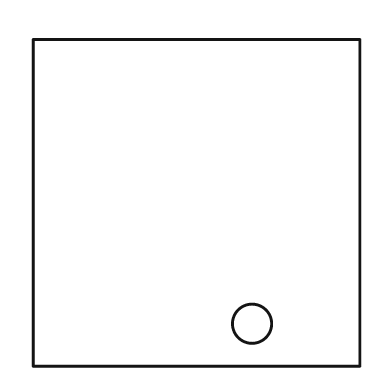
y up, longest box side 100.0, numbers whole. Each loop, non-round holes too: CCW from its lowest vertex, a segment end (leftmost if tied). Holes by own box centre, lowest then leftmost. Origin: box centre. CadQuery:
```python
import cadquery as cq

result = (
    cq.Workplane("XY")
    .moveTo(-50.0, -50.0)
    .lineTo(50.0, -50.0)
    .lineTo(50.0, 50.0)
    .lineTo(-50.0, 50.0)
    .close()
    .moveTo(17.0, -37.0)
    .circle(6.0)
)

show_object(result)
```